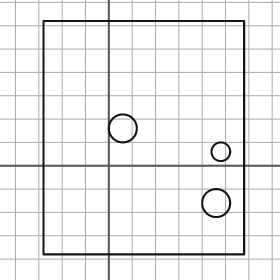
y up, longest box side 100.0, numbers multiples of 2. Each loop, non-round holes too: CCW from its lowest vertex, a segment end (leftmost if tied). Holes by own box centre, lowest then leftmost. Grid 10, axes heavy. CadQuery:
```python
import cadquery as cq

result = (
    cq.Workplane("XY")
    .moveTo(-28.0, -38.0)
    .lineTo(58.0, -38.0)
    .lineTo(58.0, 62.0)
    .lineTo(-28.0, 62.0)
    .close()
    .moveTo(46.0, -16.0)
    .circle(6.0)
    .moveTo(48.0, 6.0)
    .circle(4.0)
    .moveTo(6.0, 16.0)
    .circle(6.0)
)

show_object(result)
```